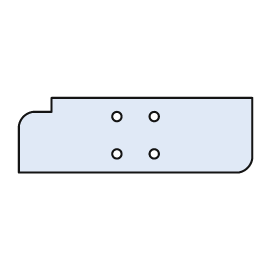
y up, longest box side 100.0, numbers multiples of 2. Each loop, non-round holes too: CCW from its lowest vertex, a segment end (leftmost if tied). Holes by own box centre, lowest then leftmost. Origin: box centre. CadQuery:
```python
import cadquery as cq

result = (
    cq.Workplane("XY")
    .moveTo(-50.0, -16.0)
    .lineTo(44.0, -16.0)
    .threePointArc((48.0, -14.0), (50.0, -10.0))
    .lineTo(50.0, 16.0)
    .lineTo(-36.0, 16.0)
    .lineTo(-36.0, 10.0)
    .lineTo(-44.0, 10.0)
    .threePointArc((-48.0, 8.0), (-50.0, 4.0))
    .close()
    .moveTo(-8.0, -8.0)
    .circle(2.0)
    .moveTo(8.0, -8.0)
    .circle(2.0)
    .moveTo(-8.0, 8.0)
    .circle(2.0)
    .moveTo(8.0, 8.0)
    .circle(2.0)
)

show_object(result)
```